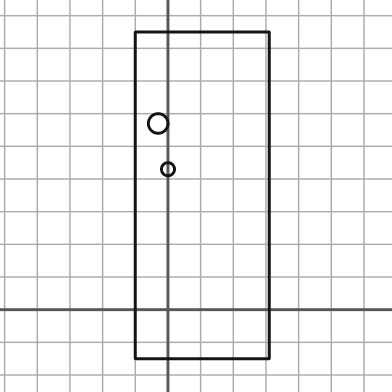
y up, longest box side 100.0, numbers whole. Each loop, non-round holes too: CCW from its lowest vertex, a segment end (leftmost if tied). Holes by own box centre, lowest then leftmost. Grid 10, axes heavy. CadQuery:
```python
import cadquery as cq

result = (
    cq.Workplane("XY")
    .moveTo(-10.0, -15.0)
    .lineTo(31.0, -15.0)
    .lineTo(31.0, 85.0)
    .lineTo(-10.0, 85.0)
    .close()
    .moveTo(0.0, 43.0)
    .circle(2.0)
    .moveTo(-3.0, 57.0)
    .circle(3.0)
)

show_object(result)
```